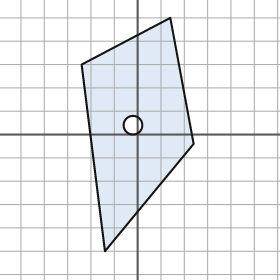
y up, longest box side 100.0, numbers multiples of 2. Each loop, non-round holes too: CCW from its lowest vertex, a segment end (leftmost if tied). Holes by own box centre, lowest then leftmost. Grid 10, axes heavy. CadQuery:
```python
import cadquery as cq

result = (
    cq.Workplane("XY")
    .moveTo(-14.0, -50.0)
    .lineTo(24.0, -4.0)
    .lineTo(14.0, 50.0)
    .lineTo(-24.0, 30.0)
    .close()
    .moveTo(-2.0, 4.0)
    .circle(4.0)
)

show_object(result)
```